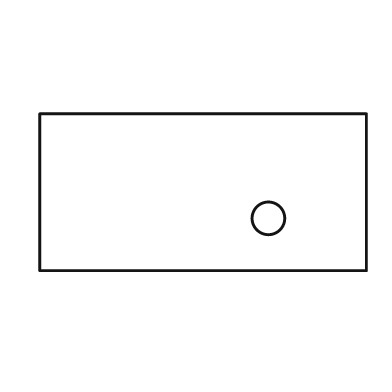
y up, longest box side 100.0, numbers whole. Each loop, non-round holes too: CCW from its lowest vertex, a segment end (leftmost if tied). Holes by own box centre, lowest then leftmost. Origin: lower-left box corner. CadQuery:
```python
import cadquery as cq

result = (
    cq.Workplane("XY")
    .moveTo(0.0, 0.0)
    .lineTo(100.0, 0.0)
    .lineTo(100.0, 48.0)
    .lineTo(0.0, 48.0)
    .close()
    .moveTo(70.0, 16.0)
    .circle(5.0)
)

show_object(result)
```